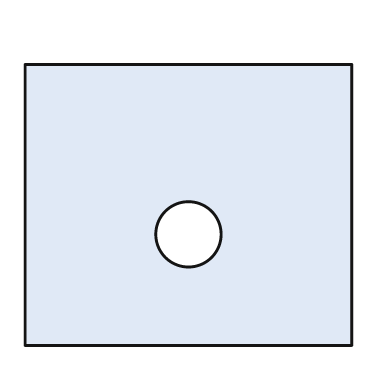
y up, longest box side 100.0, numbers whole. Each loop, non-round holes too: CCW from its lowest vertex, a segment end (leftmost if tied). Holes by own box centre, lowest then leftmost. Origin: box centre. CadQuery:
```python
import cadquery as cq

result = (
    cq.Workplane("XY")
    .moveTo(-50.0, -43.0)
    .lineTo(50.0, -43.0)
    .lineTo(50.0, 43.0)
    .lineTo(-50.0, 43.0)
    .close()
    .moveTo(0.0, -9.0)
    .circle(10.0)
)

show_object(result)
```